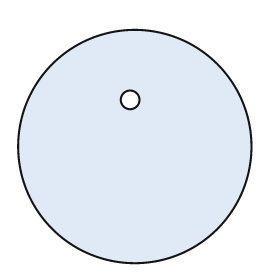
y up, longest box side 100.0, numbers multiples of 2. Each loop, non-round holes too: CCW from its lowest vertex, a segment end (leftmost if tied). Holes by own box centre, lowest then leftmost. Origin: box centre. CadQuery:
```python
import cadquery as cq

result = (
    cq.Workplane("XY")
    .moveTo(0.0, 0.0)
    .circle(50.0)
    .moveTo(-2.0, 20.0)
    .circle(4.0)
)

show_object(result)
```